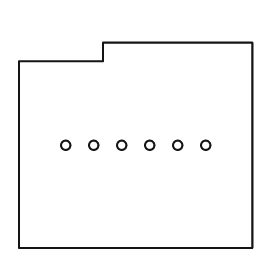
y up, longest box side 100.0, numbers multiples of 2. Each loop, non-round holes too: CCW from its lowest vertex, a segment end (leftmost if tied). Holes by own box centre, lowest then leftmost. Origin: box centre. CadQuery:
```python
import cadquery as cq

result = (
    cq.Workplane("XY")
    .moveTo(-50.0, -44.0)
    .lineTo(50.0, -44.0)
    .lineTo(50.0, 44.0)
    .lineTo(-14.0, 44.0)
    .lineTo(-14.0, 36.0)
    .lineTo(-50.0, 36.0)
    .close()
    .moveTo(-30.0, 0.0)
    .circle(2.0)
    .moveTo(-18.0, 0.0)
    .circle(2.0)
    .moveTo(-6.0, 0.0)
    .circle(2.0)
    .moveTo(6.0, 0.0)
    .circle(2.0)
    .moveTo(18.0, 0.0)
    .circle(2.0)
    .moveTo(30.0, 0.0)
    .circle(2.0)
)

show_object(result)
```